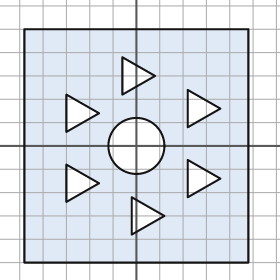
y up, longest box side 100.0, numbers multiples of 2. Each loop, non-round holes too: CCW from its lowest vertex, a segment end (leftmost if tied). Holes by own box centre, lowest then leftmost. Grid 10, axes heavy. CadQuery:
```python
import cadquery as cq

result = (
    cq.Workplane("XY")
    .moveTo(-48.0, -50.0)
    .lineTo(48.0, -50.0)
    .lineTo(48.0, 50.0)
    .lineTo(-48.0, 50.0)
    .close()
    .moveTo(-2.0, -38.0)
    .lineTo(12.0, -30.0)
    .lineTo(-2.0, -22.0)
    .close()
    .moveTo(-30.0, -24.0)
    .lineTo(-16.0, -16.0)
    .lineTo(-30.0, -8.0)
    .close()
    .moveTo(22.0, -22.0)
    .lineTo(36.0, -14.0)
    .lineTo(22.0, -6.0)
    .close()
    .moveTo(0.0, 0.0)
    .circle(12.0)
    .moveTo(-30.0, 6.0)
    .lineTo(-16.0, 14.0)
    .lineTo(-30.0, 22.0)
    .close()
    .moveTo(22.0, 8.0)
    .lineTo(36.0, 16.0)
    .lineTo(22.0, 24.0)
    .close()
    .moveTo(-6.0, 22.0)
    .lineTo(8.0, 30.0)
    .lineTo(-6.0, 38.0)
    .close()
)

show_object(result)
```